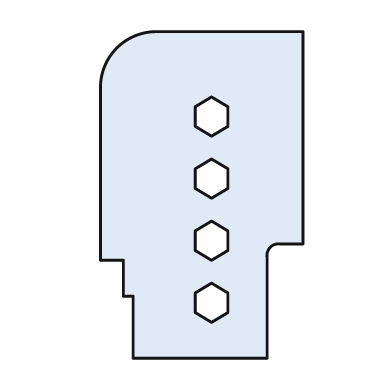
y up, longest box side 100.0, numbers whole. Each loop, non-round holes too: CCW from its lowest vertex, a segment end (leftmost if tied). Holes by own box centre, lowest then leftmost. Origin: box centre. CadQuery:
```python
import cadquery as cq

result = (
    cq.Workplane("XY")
    .moveTo(-21.0, -50.0)
    .lineTo(20.0, -50.0)
    .lineTo(20.0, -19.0)
    .threePointArc((21.0, -16.0), (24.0, -15.0))
    .lineTo(31.0, -15.0)
    .lineTo(31.0, 50.0)
    .lineTo(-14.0, 50.0)
    .threePointArc((-26.0, 45.0), (-31.0, 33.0))
    .lineTo(-31.0, -20.0)
    .lineTo(-24.0, -20.0)
    .lineTo(-24.0, -31.0)
    .lineTo(-21.0, -31.0)
    .close()
    .moveTo(3.0, -39.0)
    .lineTo(8.0, -36.0)
    .lineTo(8.0, -30.0)
    .lineTo(3.0, -27.0)
    .lineTo(-2.0, -30.0)
    .lineTo(-2.0, -36.0)
    .close()
    .moveTo(3.0, -20.0)
    .lineTo(8.0, -17.0)
    .lineTo(8.0, -11.0)
    .lineTo(3.0, -8.0)
    .lineTo(-2.0, -11.0)
    .lineTo(-2.0, -17.0)
    .close()
    .moveTo(3.0, -1.0)
    .lineTo(8.0, 2.0)
    .lineTo(8.0, 8.0)
    .lineTo(3.0, 11.0)
    .lineTo(-2.0, 8.0)
    .lineTo(-2.0, 2.0)
    .close()
    .moveTo(3.0, 18.0)
    .lineTo(8.0, 21.0)
    .lineTo(8.0, 27.0)
    .lineTo(3.0, 30.0)
    .lineTo(-2.0, 27.0)
    .lineTo(-2.0, 21.0)
    .close()
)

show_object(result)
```